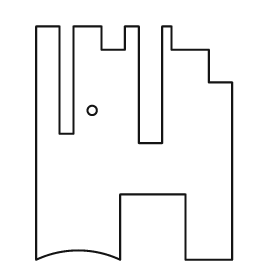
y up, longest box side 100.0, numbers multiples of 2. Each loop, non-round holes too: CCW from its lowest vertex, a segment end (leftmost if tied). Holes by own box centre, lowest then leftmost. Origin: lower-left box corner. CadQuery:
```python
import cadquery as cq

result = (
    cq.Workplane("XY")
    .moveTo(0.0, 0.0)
    .threePointArc((18.0, 4.0), (36.0, 0.0))
    .lineTo(36.0, 28.0)
    .lineTo(64.0, 28.0)
    .lineTo(64.0, 0.0)
    .lineTo(84.0, 0.0)
    .lineTo(84.0, 76.0)
    .lineTo(74.0, 76.0)
    .lineTo(74.0, 90.0)
    .lineTo(58.0, 90.0)
    .lineTo(58.0, 100.0)
    .lineTo(54.0, 100.0)
    .lineTo(54.0, 50.0)
    .lineTo(44.0, 50.0)
    .lineTo(44.0, 100.0)
    .lineTo(38.0, 100.0)
    .lineTo(38.0, 90.0)
    .lineTo(28.0, 90.0)
    .lineTo(28.0, 100.0)
    .lineTo(16.0, 100.0)
    .lineTo(16.0, 54.0)
    .lineTo(10.0, 54.0)
    .lineTo(10.0, 100.0)
    .lineTo(0.0, 100.0)
    .close()
    .moveTo(24.0, 64.0)
    .circle(2.0)
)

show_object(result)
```